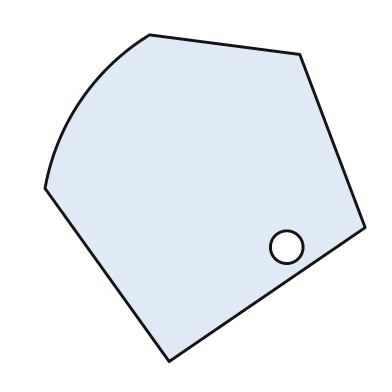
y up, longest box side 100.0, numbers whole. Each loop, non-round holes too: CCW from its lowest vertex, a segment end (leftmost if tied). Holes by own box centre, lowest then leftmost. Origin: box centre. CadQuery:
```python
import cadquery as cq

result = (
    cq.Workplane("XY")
    .moveTo(-11.0, -50.0)
    .lineTo(49.0, -9.0)
    .lineTo(29.0, 44.0)
    .lineTo(-17.0, 50.0)
    .threePointArc((-38.0, 30.0), (-49.0, 3.0))
    .close()
    .moveTo(25.0, -15.0)
    .circle(5.0)
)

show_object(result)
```